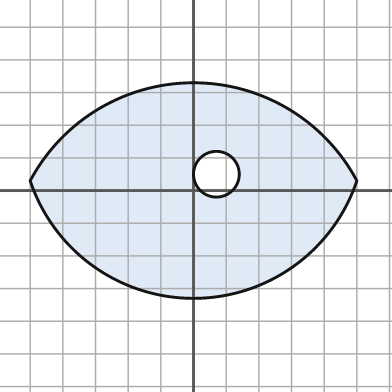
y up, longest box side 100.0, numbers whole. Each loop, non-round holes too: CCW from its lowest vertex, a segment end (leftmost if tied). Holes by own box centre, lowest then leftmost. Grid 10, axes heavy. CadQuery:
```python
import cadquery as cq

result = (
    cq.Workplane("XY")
    .moveTo(-50.0, 3.0)
    .threePointArc((0.0, -33.0), (50.0, 3.0))
    .threePointArc((0.0, 33.0), (-50.0, 3.0))
    .close()
    .moveTo(7.0, 5.0)
    .circle(7.0)
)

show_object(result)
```